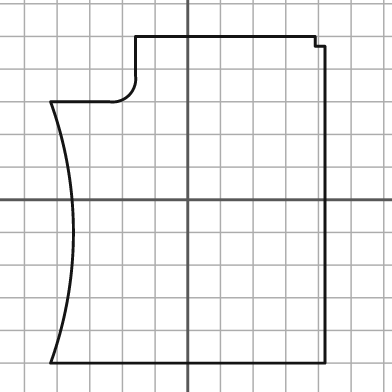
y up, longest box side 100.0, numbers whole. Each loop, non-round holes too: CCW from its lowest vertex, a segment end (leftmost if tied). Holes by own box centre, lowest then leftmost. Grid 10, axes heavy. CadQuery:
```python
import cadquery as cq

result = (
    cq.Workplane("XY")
    .moveTo(-42.0, -50.0)
    .lineTo(42.0, -50.0)
    .lineTo(42.0, 47.0)
    .lineTo(39.0, 47.0)
    .lineTo(39.0, 50.0)
    .lineTo(-16.0, 50.0)
    .lineTo(-16.0, 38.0)
    .threePointArc((-18.0, 32.0), (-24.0, 30.0))
    .lineTo(-42.0, 30.0)
    .threePointArc((-35.0, -10.0), (-42.0, -50.0))
    .close()
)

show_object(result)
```